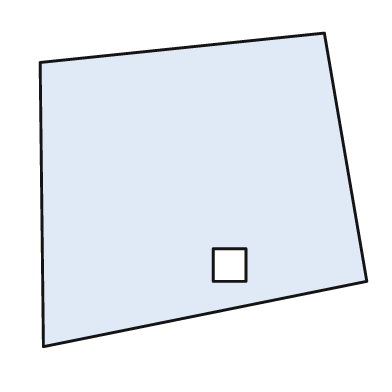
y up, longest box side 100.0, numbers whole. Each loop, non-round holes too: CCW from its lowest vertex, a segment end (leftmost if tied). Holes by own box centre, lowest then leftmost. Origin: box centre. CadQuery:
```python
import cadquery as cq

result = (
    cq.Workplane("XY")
    .moveTo(-49.0, -48.0)
    .lineTo(50.0, -28.0)
    .lineTo(37.0, 48.0)
    .lineTo(-50.0, 39.0)
    .close()
    .moveTo(3.0, -28.0)
    .lineTo(13.0, -28.0)
    .lineTo(13.0, -18.0)
    .lineTo(3.0, -18.0)
    .close()
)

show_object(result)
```